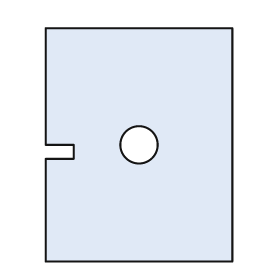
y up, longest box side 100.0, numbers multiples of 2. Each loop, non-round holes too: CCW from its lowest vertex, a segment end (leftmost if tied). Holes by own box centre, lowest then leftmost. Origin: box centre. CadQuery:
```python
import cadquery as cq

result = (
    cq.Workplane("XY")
    .moveTo(-40.0, -50.0)
    .lineTo(40.0, -50.0)
    .lineTo(40.0, 50.0)
    .lineTo(-40.0, 50.0)
    .lineTo(-40.0, 0.0)
    .lineTo(-28.0, 0.0)
    .lineTo(-28.0, -6.0)
    .lineTo(-40.0, -6.0)
    .close()
    .moveTo(0.0, 0.0)
    .circle(8.0)
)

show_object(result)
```